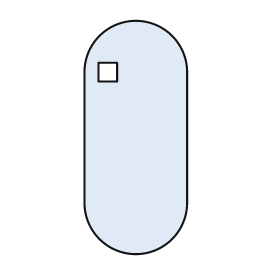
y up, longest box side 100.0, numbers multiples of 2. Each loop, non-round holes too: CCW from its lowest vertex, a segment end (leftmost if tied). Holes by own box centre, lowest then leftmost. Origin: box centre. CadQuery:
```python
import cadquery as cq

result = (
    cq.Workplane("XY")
    .moveTo(-22.0, -28.0)
    .threePointArc((0.0, -50.0), (22.0, -28.0))
    .lineTo(22.0, 28.0)
    .threePointArc((0.0, 50.0), (-22.0, 28.0))
    .close()
    .moveTo(-16.0, 24.0)
    .lineTo(-8.0, 24.0)
    .lineTo(-8.0, 32.0)
    .lineTo(-16.0, 32.0)
    .close()
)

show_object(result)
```